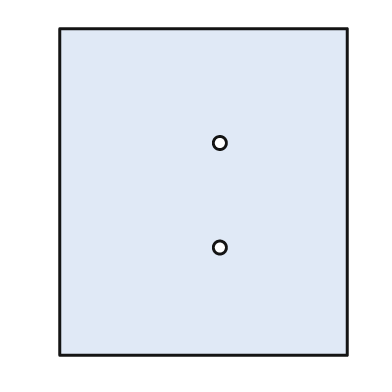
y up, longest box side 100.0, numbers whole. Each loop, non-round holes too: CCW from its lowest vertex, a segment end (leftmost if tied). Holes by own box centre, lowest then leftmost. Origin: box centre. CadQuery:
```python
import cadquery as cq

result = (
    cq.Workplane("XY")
    .moveTo(-44.0, -50.0)
    .lineTo(44.0, -50.0)
    .lineTo(44.0, 50.0)
    .lineTo(-44.0, 50.0)
    .close()
    .moveTo(5.0, -17.0)
    .circle(2.0)
    .moveTo(5.0, 15.0)
    .circle(2.0)
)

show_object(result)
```